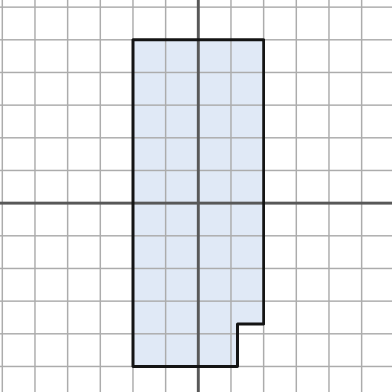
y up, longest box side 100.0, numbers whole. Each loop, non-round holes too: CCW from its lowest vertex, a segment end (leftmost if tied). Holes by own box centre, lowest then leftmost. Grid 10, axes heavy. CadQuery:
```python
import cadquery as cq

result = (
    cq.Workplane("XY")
    .moveTo(-20.0, -50.0)
    .lineTo(12.0, -50.0)
    .lineTo(12.0, -37.0)
    .lineTo(20.0, -37.0)
    .lineTo(20.0, 50.0)
    .lineTo(-20.0, 50.0)
    .close()
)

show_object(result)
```